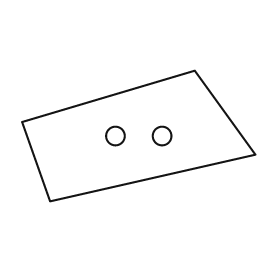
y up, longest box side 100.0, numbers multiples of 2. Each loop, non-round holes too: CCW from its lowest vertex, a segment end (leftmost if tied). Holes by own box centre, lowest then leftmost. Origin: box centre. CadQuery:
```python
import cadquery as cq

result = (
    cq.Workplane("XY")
    .moveTo(-38.0, -28.0)
    .lineTo(50.0, -8.0)
    .lineTo(24.0, 28.0)
    .lineTo(-50.0, 6.0)
    .close()
    .moveTo(-10.0, 0.0)
    .circle(4.0)
    .moveTo(10.0, 0.0)
    .circle(4.0)
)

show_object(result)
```